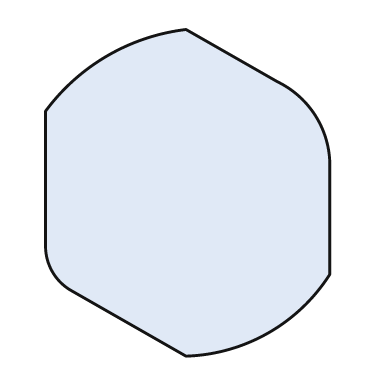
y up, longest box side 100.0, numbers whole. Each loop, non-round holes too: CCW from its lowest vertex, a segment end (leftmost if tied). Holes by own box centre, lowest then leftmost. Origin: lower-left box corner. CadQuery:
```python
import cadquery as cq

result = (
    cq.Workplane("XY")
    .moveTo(43.0, 0.0)
    .threePointArc((68.0, 7.0), (87.0, 25.0))
    .lineTo(87.0, 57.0)
    .threePointArc((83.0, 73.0), (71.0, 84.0))
    .lineTo(43.0, 100.0)
    .threePointArc((19.0, 92.0), (0.0, 75.0))
    .lineTo(0.0, 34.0)
    .threePointArc((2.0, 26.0), (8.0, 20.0))
    .close()
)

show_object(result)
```